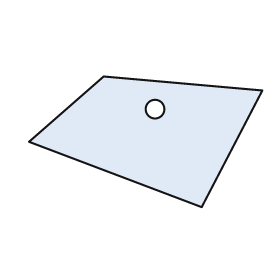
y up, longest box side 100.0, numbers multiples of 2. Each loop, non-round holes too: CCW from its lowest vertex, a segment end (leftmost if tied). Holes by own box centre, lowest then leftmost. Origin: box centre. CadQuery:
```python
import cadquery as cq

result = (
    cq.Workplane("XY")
    .moveTo(24.0, -28.0)
    .lineTo(50.0, 22.0)
    .lineTo(-18.0, 28.0)
    .lineTo(-50.0, 0.0)
    .close()
    .moveTo(4.0, 14.0)
    .circle(4.0)
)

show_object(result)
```